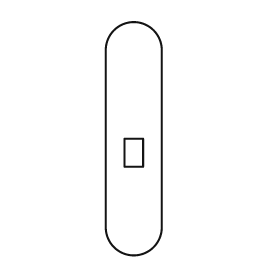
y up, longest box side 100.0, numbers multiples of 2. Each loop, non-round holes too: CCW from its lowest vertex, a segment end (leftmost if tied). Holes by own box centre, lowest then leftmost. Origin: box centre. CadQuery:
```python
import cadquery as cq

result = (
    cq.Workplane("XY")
    .moveTo(-12.0, -38.0)
    .threePointArc((0.0, -50.0), (12.0, -38.0))
    .lineTo(12.0, 38.0)
    .threePointArc((0.0, 50.0), (-12.0, 38.0))
    .close()
    .moveTo(-4.0, -12.0)
    .lineTo(4.0, -12.0)
    .lineTo(4.0, 0.0)
    .lineTo(-4.0, 0.0)
    .close()
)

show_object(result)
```